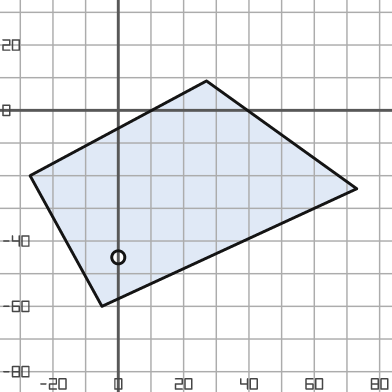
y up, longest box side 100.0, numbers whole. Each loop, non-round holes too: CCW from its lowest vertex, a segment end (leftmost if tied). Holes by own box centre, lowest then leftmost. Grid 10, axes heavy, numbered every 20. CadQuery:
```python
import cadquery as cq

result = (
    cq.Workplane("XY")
    .moveTo(-5.0, -60.0)
    .lineTo(73.0, -24.0)
    .lineTo(27.0, 9.0)
    .lineTo(-27.0, -20.0)
    .close()
    .moveTo(0.0, -45.0)
    .circle(2.0)
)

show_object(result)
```